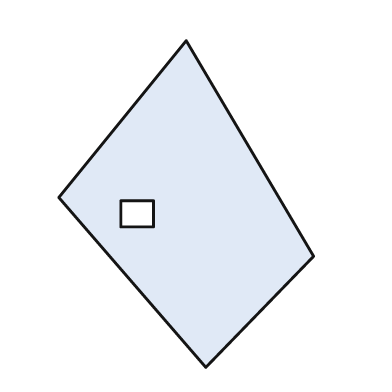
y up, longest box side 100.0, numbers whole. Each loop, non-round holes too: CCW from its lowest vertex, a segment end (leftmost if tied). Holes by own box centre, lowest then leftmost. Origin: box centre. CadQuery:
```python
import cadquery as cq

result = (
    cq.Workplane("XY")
    .moveTo(6.0, -50.0)
    .lineTo(39.0, -16.0)
    .lineTo(0.0, 50.0)
    .lineTo(-39.0, 2.0)
    .close()
    .moveTo(-20.0, -7.0)
    .lineTo(-10.0, -7.0)
    .lineTo(-10.0, 1.0)
    .lineTo(-20.0, 1.0)
    .close()
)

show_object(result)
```